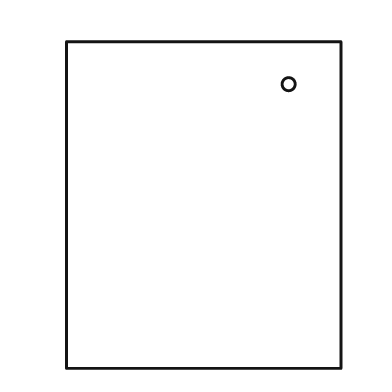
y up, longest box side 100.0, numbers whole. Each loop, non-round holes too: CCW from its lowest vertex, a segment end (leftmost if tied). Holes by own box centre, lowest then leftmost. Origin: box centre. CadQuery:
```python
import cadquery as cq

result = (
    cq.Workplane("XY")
    .moveTo(-42.0, -50.0)
    .lineTo(42.0, -50.0)
    .lineTo(42.0, 50.0)
    .lineTo(-42.0, 50.0)
    .close()
    .moveTo(26.0, 37.0)
    .circle(2.0)
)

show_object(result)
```